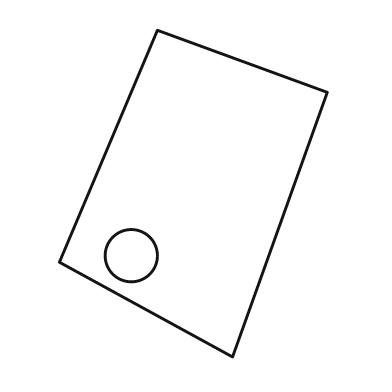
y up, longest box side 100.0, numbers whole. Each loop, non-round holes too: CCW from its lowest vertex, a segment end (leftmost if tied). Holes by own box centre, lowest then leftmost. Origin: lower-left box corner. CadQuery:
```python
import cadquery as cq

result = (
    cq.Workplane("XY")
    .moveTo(53.0, 0.0)
    .lineTo(82.0, 81.0)
    .lineTo(30.0, 100.0)
    .lineTo(0.0, 29.0)
    .close()
    .moveTo(22.0, 31.0)
    .circle(8.0)
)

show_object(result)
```